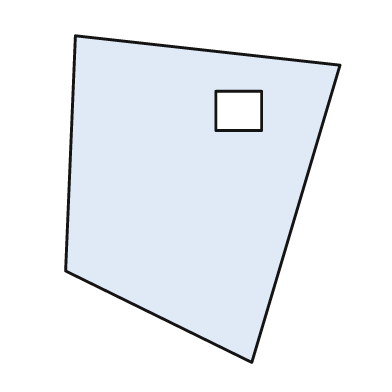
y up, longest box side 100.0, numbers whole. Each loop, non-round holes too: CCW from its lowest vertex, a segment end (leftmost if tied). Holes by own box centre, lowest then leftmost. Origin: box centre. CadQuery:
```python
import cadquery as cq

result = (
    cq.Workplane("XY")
    .moveTo(15.0, -50.0)
    .lineTo(42.0, 41.0)
    .lineTo(-39.0, 50.0)
    .lineTo(-42.0, -22.0)
    .close()
    .moveTo(4.0, 21.0)
    .lineTo(18.0, 21.0)
    .lineTo(18.0, 33.0)
    .lineTo(4.0, 33.0)
    .close()
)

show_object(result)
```